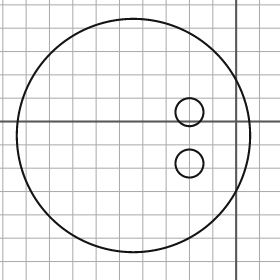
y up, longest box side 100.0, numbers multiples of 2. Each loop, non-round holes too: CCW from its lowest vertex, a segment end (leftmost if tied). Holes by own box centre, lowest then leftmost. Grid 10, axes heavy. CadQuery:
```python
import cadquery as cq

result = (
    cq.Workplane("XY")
    .moveTo(-44.0, -6.0)
    .circle(50.0)
    .moveTo(-20.0, -18.0)
    .circle(6.0)
    .moveTo(-20.0, 4.0)
    .circle(6.0)
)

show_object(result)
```